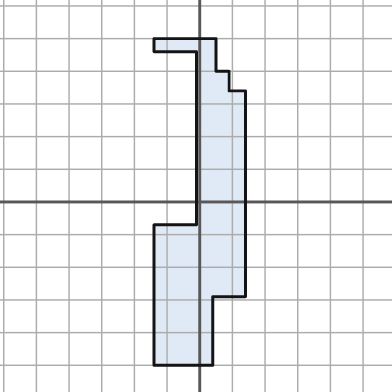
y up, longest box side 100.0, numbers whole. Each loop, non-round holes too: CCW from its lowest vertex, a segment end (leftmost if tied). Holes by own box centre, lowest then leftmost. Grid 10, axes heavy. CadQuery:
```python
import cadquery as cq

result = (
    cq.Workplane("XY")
    .moveTo(-14.0, -50.0)
    .lineTo(4.0, -50.0)
    .lineTo(4.0, -29.0)
    .lineTo(14.0, -29.0)
    .lineTo(14.0, 34.0)
    .lineTo(9.0, 34.0)
    .lineTo(9.0, 40.0)
    .lineTo(5.0, 40.0)
    .lineTo(5.0, 50.0)
    .lineTo(-14.0, 50.0)
    .lineTo(-14.0, 46.0)
    .lineTo(-1.0, 46.0)
    .lineTo(-1.0, -7.0)
    .lineTo(-14.0, -7.0)
    .close()
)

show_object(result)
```